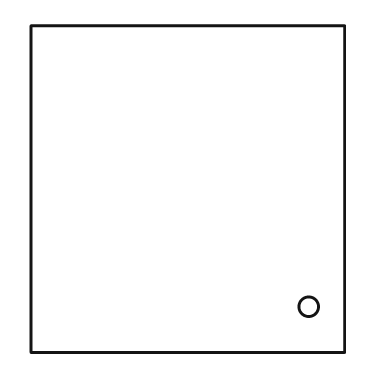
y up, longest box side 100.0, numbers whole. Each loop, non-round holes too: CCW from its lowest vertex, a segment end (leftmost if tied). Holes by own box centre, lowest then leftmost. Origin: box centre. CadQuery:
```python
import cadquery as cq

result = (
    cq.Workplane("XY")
    .moveTo(-48.0, -50.0)
    .lineTo(48.0, -50.0)
    .lineTo(48.0, 50.0)
    .lineTo(-48.0, 50.0)
    .close()
    .moveTo(37.0, -36.0)
    .circle(3.0)
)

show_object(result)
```